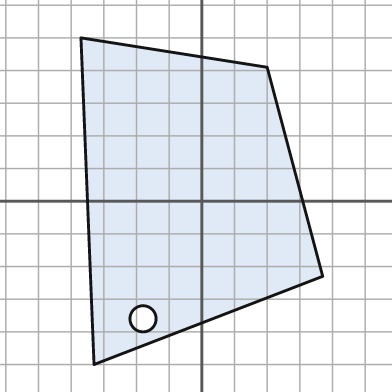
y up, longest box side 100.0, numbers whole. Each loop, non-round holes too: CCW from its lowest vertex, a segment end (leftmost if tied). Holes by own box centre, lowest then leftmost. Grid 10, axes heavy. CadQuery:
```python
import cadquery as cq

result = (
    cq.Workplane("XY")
    .moveTo(-33.0, -50.0)
    .lineTo(37.0, -23.0)
    .lineTo(20.0, 41.0)
    .lineTo(-37.0, 50.0)
    .close()
    .moveTo(-18.0, -36.0)
    .circle(4.0)
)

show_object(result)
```